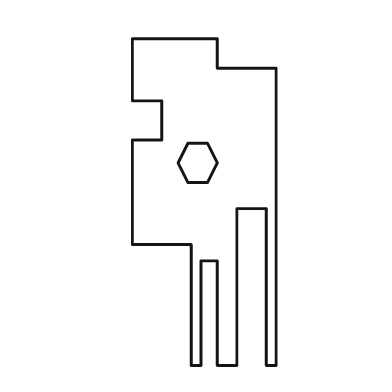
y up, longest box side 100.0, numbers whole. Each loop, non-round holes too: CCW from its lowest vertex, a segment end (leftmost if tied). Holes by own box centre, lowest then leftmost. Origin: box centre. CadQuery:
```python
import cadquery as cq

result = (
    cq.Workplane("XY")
    .moveTo(-4.0, -50.0)
    .lineTo(-1.0, -50.0)
    .lineTo(-1.0, -18.0)
    .lineTo(4.0, -18.0)
    .lineTo(4.0, -50.0)
    .lineTo(10.0, -50.0)
    .lineTo(10.0, -2.0)
    .lineTo(19.0, -2.0)
    .lineTo(19.0, -50.0)
    .lineTo(22.0, -50.0)
    .lineTo(22.0, 41.0)
    .lineTo(4.0, 41.0)
    .lineTo(4.0, 50.0)
    .lineTo(-22.0, 50.0)
    .lineTo(-22.0, 31.0)
    .lineTo(-13.0, 31.0)
    .lineTo(-13.0, 19.0)
    .lineTo(-22.0, 19.0)
    .lineTo(-22.0, -13.0)
    .lineTo(-4.0, -13.0)
    .close()
    .moveTo(-5.0, 6.0)
    .lineTo(1.0, 6.0)
    .lineTo(4.0, 12.0)
    .lineTo(1.0, 18.0)
    .lineTo(-5.0, 18.0)
    .lineTo(-8.0, 12.0)
    .close()
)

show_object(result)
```